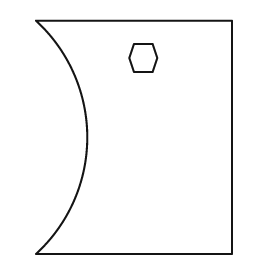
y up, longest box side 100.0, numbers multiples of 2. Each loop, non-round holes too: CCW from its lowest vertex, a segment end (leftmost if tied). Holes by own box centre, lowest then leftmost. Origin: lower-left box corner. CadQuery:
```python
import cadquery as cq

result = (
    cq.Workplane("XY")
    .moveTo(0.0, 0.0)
    .lineTo(84.0, 0.0)
    .lineTo(84.0, 100.0)
    .lineTo(0.0, 100.0)
    .threePointArc((22.0, 50.0), (0.0, 0.0))
    .close()
    .moveTo(42.0, 78.0)
    .lineTo(50.0, 78.0)
    .lineTo(52.0, 84.0)
    .lineTo(50.0, 90.0)
    .lineTo(42.0, 90.0)
    .lineTo(40.0, 84.0)
    .close()
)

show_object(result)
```